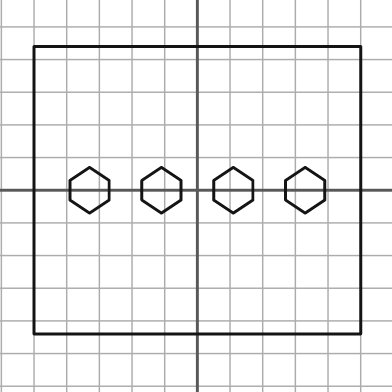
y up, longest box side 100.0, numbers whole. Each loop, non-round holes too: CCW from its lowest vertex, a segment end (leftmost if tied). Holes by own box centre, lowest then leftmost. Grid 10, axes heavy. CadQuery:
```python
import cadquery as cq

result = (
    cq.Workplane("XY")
    .moveTo(-50.0, -44.0)
    .lineTo(50.0, -44.0)
    .lineTo(50.0, 44.0)
    .lineTo(-50.0, 44.0)
    .close()
    .moveTo(-33.0, -7.0)
    .lineTo(-27.0, -3.0)
    .lineTo(-27.0, 3.0)
    .lineTo(-33.0, 7.0)
    .lineTo(-39.0, 3.0)
    .lineTo(-39.0, -3.0)
    .close()
    .moveTo(-11.0, -7.0)
    .lineTo(-5.0, -3.0)
    .lineTo(-5.0, 3.0)
    .lineTo(-11.0, 7.0)
    .lineTo(-17.0, 3.0)
    .lineTo(-17.0, -3.0)
    .close()
    .moveTo(11.0, -7.0)
    .lineTo(17.0, -3.0)
    .lineTo(17.0, 3.0)
    .lineTo(11.0, 7.0)
    .lineTo(5.0, 3.0)
    .lineTo(5.0, -3.0)
    .close()
    .moveTo(33.0, -7.0)
    .lineTo(39.0, -3.0)
    .lineTo(39.0, 3.0)
    .lineTo(33.0, 7.0)
    .lineTo(27.0, 3.0)
    .lineTo(27.0, -3.0)
    .close()
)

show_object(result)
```